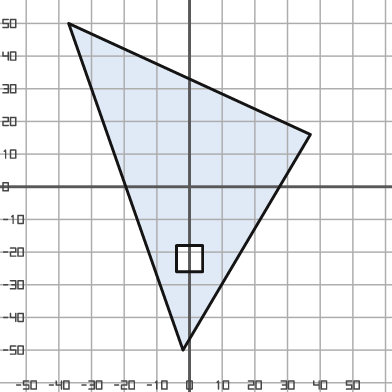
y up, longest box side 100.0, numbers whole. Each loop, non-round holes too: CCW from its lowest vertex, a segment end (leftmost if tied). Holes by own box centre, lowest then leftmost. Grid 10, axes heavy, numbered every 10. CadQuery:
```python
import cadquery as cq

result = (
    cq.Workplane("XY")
    .moveTo(-2.0, -50.0)
    .lineTo(37.0, 16.0)
    .lineTo(-37.0, 50.0)
    .close()
    .moveTo(-4.0, -26.0)
    .lineTo(4.0, -26.0)
    .lineTo(4.0, -18.0)
    .lineTo(-4.0, -18.0)
    .close()
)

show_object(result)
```